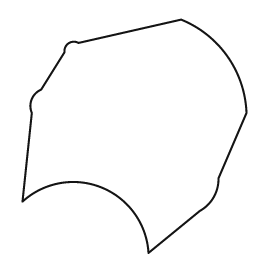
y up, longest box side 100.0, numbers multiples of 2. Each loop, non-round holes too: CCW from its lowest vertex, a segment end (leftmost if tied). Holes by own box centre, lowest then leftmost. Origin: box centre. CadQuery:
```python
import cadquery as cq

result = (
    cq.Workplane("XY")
    .moveTo(6.0, -50.0)
    .lineTo(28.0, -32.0)
    .threePointArc((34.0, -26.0), (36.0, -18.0))
    .lineTo(48.0, 10.0)
    .threePointArc((40.0, 34.0), (20.0, 50.0))
    .lineTo(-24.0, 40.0)
    .threePointArc((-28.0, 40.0), (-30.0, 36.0))
    .lineTo(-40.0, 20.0)
    .threePointArc((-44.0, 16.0), (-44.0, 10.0))
    .lineTo(-48.0, -28.0)
    .threePointArc((-14.0, -22.0), (6.0, -50.0))
    .close()
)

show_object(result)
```